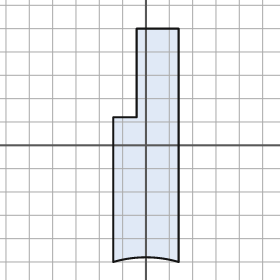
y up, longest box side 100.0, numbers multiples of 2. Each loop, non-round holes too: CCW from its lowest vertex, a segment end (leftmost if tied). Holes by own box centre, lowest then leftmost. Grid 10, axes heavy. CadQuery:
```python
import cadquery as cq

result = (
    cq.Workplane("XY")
    .moveTo(-14.0, -50.0)
    .threePointArc((0.0, -48.0), (14.0, -50.0))
    .lineTo(14.0, 50.0)
    .lineTo(-4.0, 50.0)
    .lineTo(-4.0, 12.0)
    .lineTo(-14.0, 12.0)
    .close()
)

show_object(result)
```